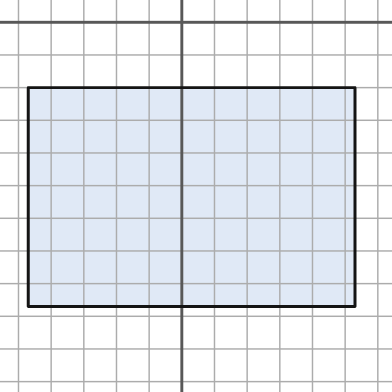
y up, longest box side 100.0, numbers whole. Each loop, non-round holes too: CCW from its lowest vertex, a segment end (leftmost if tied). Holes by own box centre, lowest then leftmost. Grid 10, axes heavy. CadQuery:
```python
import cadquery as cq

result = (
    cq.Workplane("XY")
    .moveTo(-47.0, -87.0)
    .lineTo(53.0, -87.0)
    .lineTo(53.0, -20.0)
    .lineTo(-47.0, -20.0)
    .close()
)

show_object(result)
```